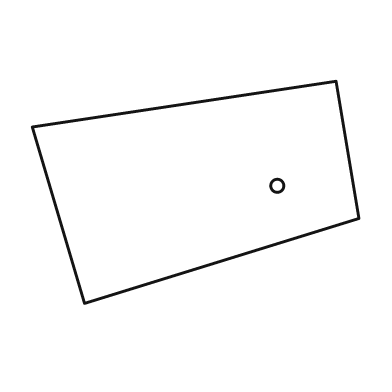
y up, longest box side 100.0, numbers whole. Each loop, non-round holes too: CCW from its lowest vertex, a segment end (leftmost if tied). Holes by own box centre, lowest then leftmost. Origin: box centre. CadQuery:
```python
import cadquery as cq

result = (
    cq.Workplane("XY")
    .moveTo(-34.0, -34.0)
    .lineTo(50.0, -8.0)
    .lineTo(43.0, 34.0)
    .lineTo(-50.0, 20.0)
    .close()
    .moveTo(25.0, 2.0)
    .circle(2.0)
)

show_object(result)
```